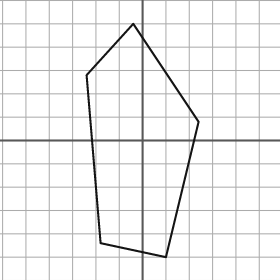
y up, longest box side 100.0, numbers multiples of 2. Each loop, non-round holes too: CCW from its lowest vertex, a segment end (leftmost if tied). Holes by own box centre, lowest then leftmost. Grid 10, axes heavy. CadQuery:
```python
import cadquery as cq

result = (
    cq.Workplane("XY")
    .moveTo(10.0, -50.0)
    .lineTo(24.0, 8.0)
    .lineTo(-4.0, 50.0)
    .lineTo(-24.0, 28.0)
    .lineTo(-18.0, -44.0)
    .close()
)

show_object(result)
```